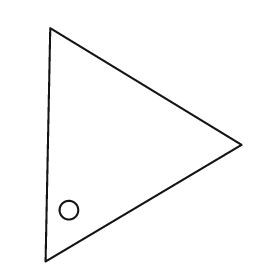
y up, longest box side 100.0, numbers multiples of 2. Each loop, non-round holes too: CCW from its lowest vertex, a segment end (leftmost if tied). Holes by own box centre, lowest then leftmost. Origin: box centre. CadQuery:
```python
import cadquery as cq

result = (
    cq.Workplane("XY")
    .moveTo(-42.0, -50.0)
    .lineTo(42.0, 0.0)
    .lineTo(-40.0, 50.0)
    .close()
    .moveTo(-32.0, -28.0)
    .circle(4.0)
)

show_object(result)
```